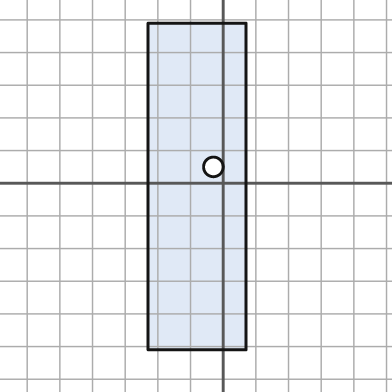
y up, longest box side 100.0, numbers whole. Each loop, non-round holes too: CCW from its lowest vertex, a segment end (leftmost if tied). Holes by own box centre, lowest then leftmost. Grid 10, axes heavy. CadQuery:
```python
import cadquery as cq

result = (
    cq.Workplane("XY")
    .moveTo(-23.0, -51.0)
    .lineTo(7.0, -51.0)
    .lineTo(7.0, 49.0)
    .lineTo(-23.0, 49.0)
    .close()
    .moveTo(-3.0, 5.0)
    .circle(3.0)
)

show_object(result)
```